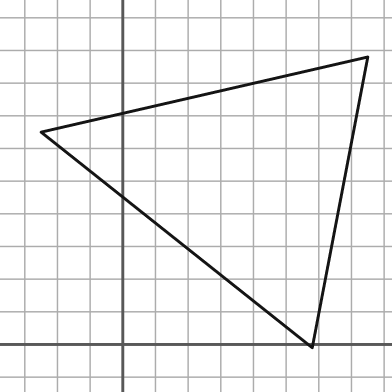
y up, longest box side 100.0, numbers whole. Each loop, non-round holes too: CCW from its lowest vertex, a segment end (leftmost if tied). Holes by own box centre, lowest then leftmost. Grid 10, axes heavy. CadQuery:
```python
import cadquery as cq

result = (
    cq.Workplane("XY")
    .moveTo(58.0, -1.0)
    .lineTo(75.0, 88.0)
    .lineTo(-25.0, 65.0)
    .close()
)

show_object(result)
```